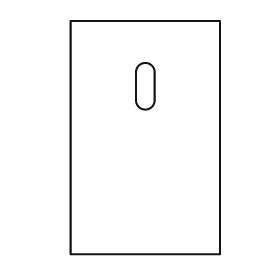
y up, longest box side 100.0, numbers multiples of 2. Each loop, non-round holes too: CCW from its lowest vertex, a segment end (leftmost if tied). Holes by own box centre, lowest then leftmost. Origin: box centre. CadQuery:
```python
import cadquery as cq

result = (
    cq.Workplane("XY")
    .moveTo(-32.0, -50.0)
    .lineTo(32.0, -50.0)
    .lineTo(32.0, 50.0)
    .lineTo(-32.0, 50.0)
    .close()
    .moveTo(-4.0, 16.0)
    .threePointArc((0.0, 12.0), (4.0, 16.0))
    .lineTo(4.0, 28.0)
    .threePointArc((0.0, 32.0), (-4.0, 28.0))
    .close()
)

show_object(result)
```